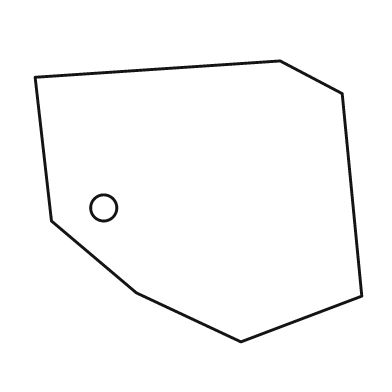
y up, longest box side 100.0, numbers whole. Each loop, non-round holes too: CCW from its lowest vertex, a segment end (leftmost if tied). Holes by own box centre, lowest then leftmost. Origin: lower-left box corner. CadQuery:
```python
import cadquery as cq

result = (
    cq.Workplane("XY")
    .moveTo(63.0, 0.0)
    .lineTo(100.0, 14.0)
    .lineTo(94.0, 76.0)
    .lineTo(75.0, 86.0)
    .lineTo(0.0, 81.0)
    .lineTo(5.0, 37.0)
    .lineTo(31.0, 15.0)
    .close()
    .moveTo(21.0, 41.0)
    .circle(4.0)
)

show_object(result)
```